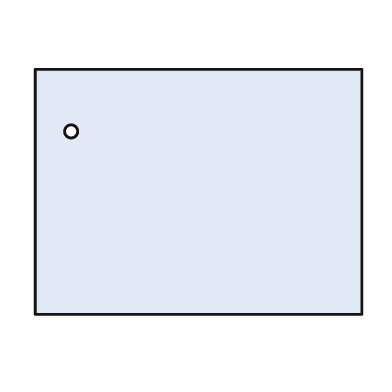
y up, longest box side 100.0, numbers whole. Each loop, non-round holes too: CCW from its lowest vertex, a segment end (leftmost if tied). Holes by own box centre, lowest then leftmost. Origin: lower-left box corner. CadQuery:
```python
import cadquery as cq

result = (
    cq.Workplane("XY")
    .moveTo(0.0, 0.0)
    .lineTo(100.0, 0.0)
    .lineTo(100.0, 75.0)
    .lineTo(0.0, 75.0)
    .close()
    .moveTo(11.0, 56.0)
    .circle(2.0)
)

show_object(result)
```